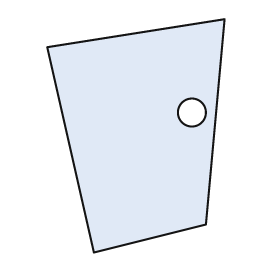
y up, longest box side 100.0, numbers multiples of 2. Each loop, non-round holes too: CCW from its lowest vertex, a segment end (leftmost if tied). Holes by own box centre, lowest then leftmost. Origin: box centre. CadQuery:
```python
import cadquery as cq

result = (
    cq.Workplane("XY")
    .moveTo(-18.0, -50.0)
    .lineTo(30.0, -38.0)
    .lineTo(38.0, 50.0)
    .lineTo(-38.0, 38.0)
    .close()
    .moveTo(24.0, 10.0)
    .circle(6.0)
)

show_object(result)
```